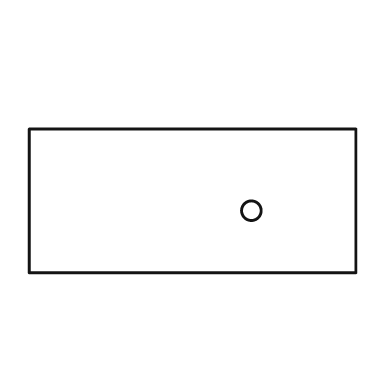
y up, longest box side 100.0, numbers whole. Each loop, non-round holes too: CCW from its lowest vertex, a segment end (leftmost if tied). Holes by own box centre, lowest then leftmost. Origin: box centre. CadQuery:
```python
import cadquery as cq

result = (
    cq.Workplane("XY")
    .moveTo(-50.0, -22.0)
    .lineTo(50.0, -22.0)
    .lineTo(50.0, 22.0)
    .lineTo(-50.0, 22.0)
    .close()
    .moveTo(18.0, -3.0)
    .circle(3.0)
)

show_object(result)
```